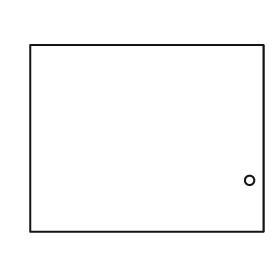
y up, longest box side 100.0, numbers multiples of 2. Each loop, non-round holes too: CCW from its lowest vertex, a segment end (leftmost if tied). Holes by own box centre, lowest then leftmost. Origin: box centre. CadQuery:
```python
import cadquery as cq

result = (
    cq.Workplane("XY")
    .moveTo(-50.0, -40.0)
    .lineTo(50.0, -40.0)
    .lineTo(50.0, 40.0)
    .lineTo(-50.0, 40.0)
    .close()
    .moveTo(44.0, -18.0)
    .circle(2.0)
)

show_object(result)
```